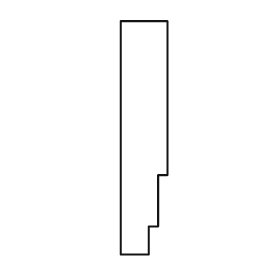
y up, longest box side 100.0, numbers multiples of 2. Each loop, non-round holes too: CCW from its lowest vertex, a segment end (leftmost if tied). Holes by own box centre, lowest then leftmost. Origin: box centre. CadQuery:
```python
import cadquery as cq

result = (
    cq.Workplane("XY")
    .moveTo(-10.0, -50.0)
    .lineTo(2.0, -50.0)
    .lineTo(2.0, -38.0)
    .lineTo(6.0, -38.0)
    .lineTo(6.0, -16.0)
    .lineTo(10.0, -16.0)
    .lineTo(10.0, 50.0)
    .lineTo(-10.0, 50.0)
    .close()
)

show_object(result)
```